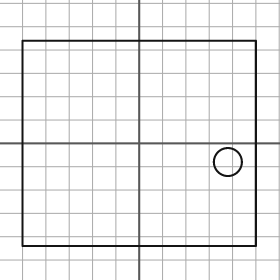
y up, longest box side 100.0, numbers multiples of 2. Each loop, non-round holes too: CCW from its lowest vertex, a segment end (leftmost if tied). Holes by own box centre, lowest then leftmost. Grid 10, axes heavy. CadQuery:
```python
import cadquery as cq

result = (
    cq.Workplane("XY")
    .moveTo(-50.0, -44.0)
    .lineTo(50.0, -44.0)
    .lineTo(50.0, 44.0)
    .lineTo(-50.0, 44.0)
    .close()
    .moveTo(38.0, -8.0)
    .circle(6.0)
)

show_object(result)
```